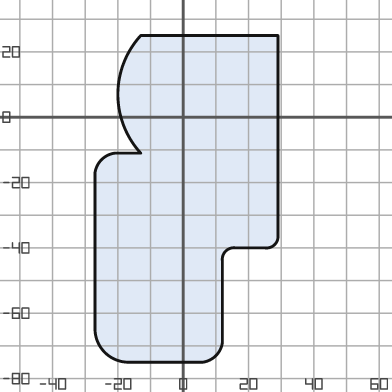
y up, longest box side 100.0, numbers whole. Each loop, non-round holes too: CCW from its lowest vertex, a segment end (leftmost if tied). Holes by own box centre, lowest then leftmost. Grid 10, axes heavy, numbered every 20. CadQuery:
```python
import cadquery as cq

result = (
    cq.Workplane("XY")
    .moveTo(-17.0, -75.0)
    .lineTo(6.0, -75.0)
    .threePointArc((10.0, -73.0), (12.0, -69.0))
    .lineTo(12.0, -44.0)
    .threePointArc((13.0, -41.0), (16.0, -40.0))
    .lineTo(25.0, -40.0)
    .threePointArc((28.0, -39.0), (29.0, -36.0))
    .lineTo(29.0, 25.0)
    .lineTo(-13.0, 25.0)
    .threePointArc((-20.0, 7.0), (-13.0, -11.0))
    .lineTo(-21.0, -11.0)
    .threePointArc((-25.0, -13.0), (-27.0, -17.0))
    .lineTo(-27.0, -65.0)
    .threePointArc((-24.0, -72.0), (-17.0, -75.0))
    .close()
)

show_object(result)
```